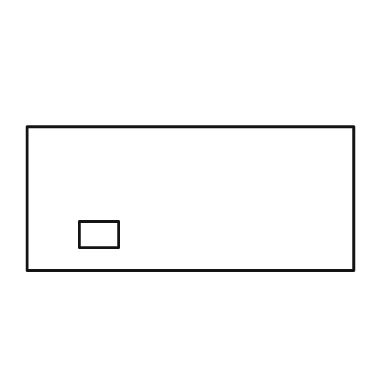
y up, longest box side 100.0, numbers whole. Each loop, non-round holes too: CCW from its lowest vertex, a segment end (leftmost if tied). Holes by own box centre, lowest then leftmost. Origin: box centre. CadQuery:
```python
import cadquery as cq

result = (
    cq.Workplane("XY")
    .moveTo(-50.0, -22.0)
    .lineTo(50.0, -22.0)
    .lineTo(50.0, 22.0)
    .lineTo(-50.0, 22.0)
    .close()
    .moveTo(-34.0, -15.0)
    .lineTo(-22.0, -15.0)
    .lineTo(-22.0, -7.0)
    .lineTo(-34.0, -7.0)
    .close()
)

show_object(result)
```